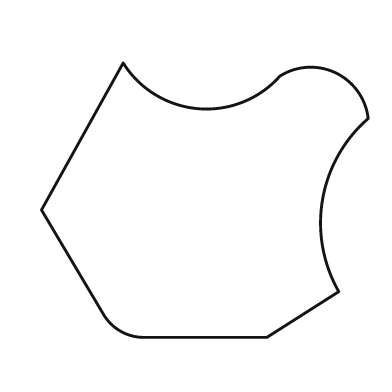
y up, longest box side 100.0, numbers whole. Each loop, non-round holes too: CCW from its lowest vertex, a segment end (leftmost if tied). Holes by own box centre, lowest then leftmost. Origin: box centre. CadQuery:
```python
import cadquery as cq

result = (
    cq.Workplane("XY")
    .moveTo(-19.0, -42.0)
    .lineTo(19.0, -42.0)
    .lineTo(41.0, -28.0)
    .threePointArc((36.0, 0.0), (50.0, 25.0))
    .threePointArc((40.0, 39.0), (23.0, 38.0))
    .threePointArc((-2.0, 28.0), (-25.0, 42.0))
    .lineTo(-50.0, -3.0)
    .lineTo(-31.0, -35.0)
    .threePointArc((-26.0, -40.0), (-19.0, -42.0))
    .close()
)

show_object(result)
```